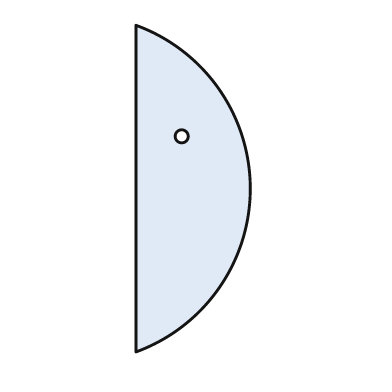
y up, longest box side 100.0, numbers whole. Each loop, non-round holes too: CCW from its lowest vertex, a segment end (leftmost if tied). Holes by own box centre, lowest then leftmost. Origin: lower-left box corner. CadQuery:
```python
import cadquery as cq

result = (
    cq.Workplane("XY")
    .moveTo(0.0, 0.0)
    .threePointArc((35.0, 50.0), (0.0, 100.0))
    .close()
    .moveTo(14.0, 66.0)
    .circle(2.0)
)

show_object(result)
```